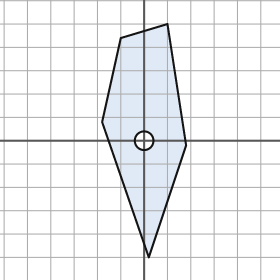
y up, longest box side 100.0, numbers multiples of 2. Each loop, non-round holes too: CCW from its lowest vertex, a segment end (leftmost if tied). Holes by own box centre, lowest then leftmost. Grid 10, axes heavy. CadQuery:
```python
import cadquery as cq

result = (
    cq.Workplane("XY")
    .moveTo(2.0, -50.0)
    .lineTo(18.0, -2.0)
    .lineTo(10.0, 50.0)
    .lineTo(-10.0, 44.0)
    .lineTo(-18.0, 8.0)
    .close()
    .moveTo(0.0, 0.0)
    .circle(4.0)
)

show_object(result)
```